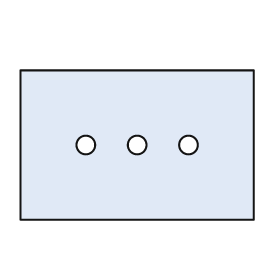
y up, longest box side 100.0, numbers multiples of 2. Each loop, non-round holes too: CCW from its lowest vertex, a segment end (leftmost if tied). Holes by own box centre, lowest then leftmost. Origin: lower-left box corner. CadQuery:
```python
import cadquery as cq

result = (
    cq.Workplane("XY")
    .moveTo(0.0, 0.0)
    .lineTo(100.0, 0.0)
    .lineTo(100.0, 64.0)
    .lineTo(0.0, 64.0)
    .close()
    .moveTo(28.0, 32.0)
    .circle(4.0)
    .moveTo(50.0, 32.0)
    .circle(4.0)
    .moveTo(72.0, 32.0)
    .circle(4.0)
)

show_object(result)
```